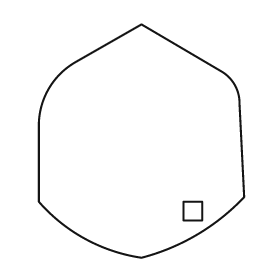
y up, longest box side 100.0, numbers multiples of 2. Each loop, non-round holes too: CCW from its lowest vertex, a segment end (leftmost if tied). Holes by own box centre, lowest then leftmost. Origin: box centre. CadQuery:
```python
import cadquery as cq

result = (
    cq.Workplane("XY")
    .moveTo(0.0, -50.0)
    .threePointArc((24.0, -40.0), (44.0, -24.0))
    .lineTo(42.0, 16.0)
    .threePointArc((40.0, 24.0), (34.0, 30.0))
    .lineTo(0.0, 50.0)
    .lineTo(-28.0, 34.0)
    .threePointArc((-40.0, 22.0), (-44.0, 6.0))
    .lineTo(-44.0, -26.0)
    .threePointArc((-24.0, -42.0), (0.0, -50.0))
    .close()
    .moveTo(18.0, -34.0)
    .lineTo(26.0, -34.0)
    .lineTo(26.0, -26.0)
    .lineTo(18.0, -26.0)
    .close()
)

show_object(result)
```